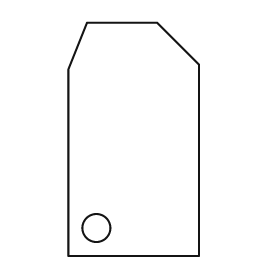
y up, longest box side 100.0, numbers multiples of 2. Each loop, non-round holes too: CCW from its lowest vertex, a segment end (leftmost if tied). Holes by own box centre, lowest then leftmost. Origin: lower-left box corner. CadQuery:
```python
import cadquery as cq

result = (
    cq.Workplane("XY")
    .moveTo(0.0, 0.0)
    .lineTo(56.0, 0.0)
    .lineTo(56.0, 82.0)
    .lineTo(38.0, 100.0)
    .lineTo(8.0, 100.0)
    .lineTo(0.0, 80.0)
    .close()
    .moveTo(12.0, 12.0)
    .circle(6.0)
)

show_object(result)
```